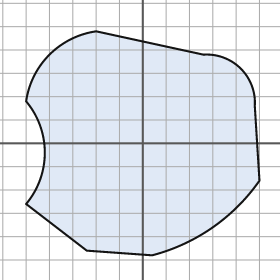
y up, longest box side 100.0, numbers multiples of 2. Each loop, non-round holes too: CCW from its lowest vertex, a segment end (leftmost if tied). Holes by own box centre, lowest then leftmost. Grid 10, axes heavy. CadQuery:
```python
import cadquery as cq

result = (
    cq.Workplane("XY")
    .moveTo(4.0, -48.0)
    .threePointArc((30.0, -36.0), (50.0, -16.0))
    .lineTo(48.0, 16.0)
    .threePointArc((42.0, 32.0), (26.0, 38.0))
    .lineTo(-20.0, 48.0)
    .threePointArc((-40.0, 38.0), (-50.0, 18.0))
    .threePointArc((-42.0, -4.0), (-50.0, -26.0))
    .lineTo(-24.0, -46.0)
    .close()
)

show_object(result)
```